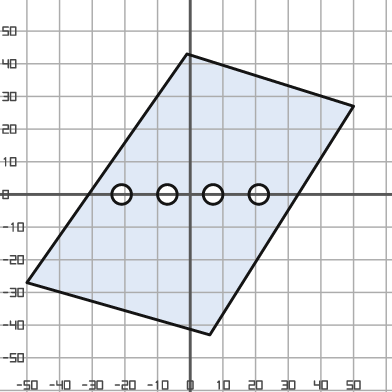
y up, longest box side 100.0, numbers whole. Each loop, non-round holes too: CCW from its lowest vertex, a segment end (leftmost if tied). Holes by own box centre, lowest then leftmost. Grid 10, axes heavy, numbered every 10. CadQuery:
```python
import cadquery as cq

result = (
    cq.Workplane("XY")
    .moveTo(6.0, -43.0)
    .lineTo(50.0, 27.0)
    .lineTo(-1.0, 43.0)
    .lineTo(-50.0, -27.0)
    .close()
    .moveTo(-21.0, 0.0)
    .circle(3.0)
    .moveTo(-7.0, 0.0)
    .circle(3.0)
    .moveTo(7.0, 0.0)
    .circle(3.0)
    .moveTo(21.0, 0.0)
    .circle(3.0)
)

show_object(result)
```